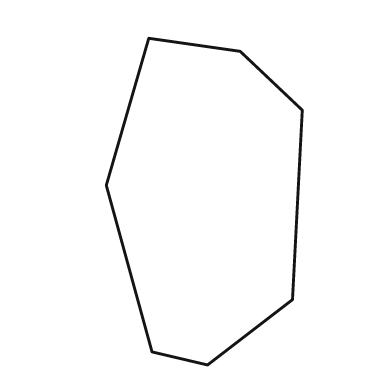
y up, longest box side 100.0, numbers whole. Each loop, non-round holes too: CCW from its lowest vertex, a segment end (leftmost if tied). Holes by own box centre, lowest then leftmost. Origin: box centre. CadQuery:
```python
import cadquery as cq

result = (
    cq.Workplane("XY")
    .moveTo(1.0, -50.0)
    .lineTo(27.0, -30.0)
    .lineTo(30.0, 28.0)
    .lineTo(11.0, 46.0)
    .lineTo(-17.0, 50.0)
    .lineTo(-30.0, 5.0)
    .lineTo(-16.0, -46.0)
    .close()
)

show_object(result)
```